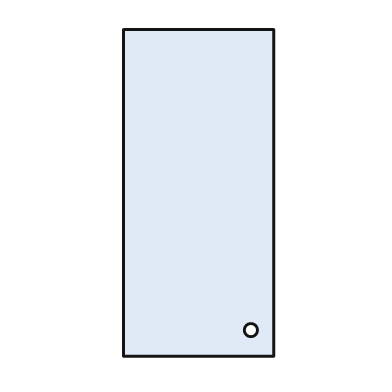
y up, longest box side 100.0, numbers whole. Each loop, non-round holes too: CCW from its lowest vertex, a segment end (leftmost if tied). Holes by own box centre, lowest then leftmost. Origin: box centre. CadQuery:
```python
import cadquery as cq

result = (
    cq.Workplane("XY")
    .moveTo(-23.0, -50.0)
    .lineTo(23.0, -50.0)
    .lineTo(23.0, 50.0)
    .lineTo(-23.0, 50.0)
    .close()
    .moveTo(16.0, -42.0)
    .circle(2.0)
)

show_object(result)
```